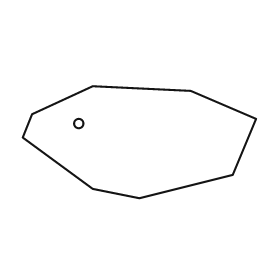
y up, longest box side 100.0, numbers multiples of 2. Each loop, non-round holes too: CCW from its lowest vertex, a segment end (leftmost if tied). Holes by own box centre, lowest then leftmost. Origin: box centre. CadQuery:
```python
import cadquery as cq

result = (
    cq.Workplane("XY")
    .moveTo(0.0, -24.0)
    .lineTo(40.0, -14.0)
    .lineTo(50.0, 10.0)
    .lineTo(22.0, 22.0)
    .lineTo(-20.0, 24.0)
    .lineTo(-46.0, 12.0)
    .lineTo(-50.0, 2.0)
    .lineTo(-20.0, -20.0)
    .close()
    .moveTo(-26.0, 8.0)
    .circle(2.0)
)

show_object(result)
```